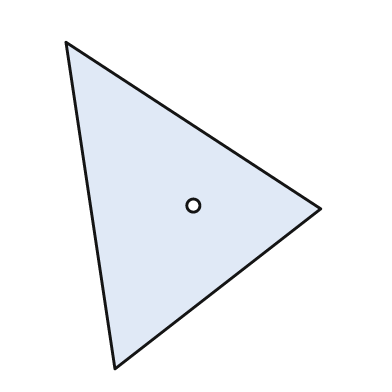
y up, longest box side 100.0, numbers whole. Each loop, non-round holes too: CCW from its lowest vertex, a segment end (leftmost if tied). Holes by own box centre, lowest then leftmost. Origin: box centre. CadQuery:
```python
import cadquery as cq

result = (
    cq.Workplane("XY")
    .moveTo(-24.0, -50.0)
    .lineTo(39.0, -1.0)
    .lineTo(-39.0, 50.0)
    .close()
    .moveTo(0.0, 0.0)
    .circle(2.0)
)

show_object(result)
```